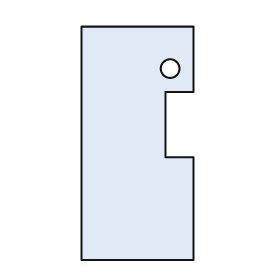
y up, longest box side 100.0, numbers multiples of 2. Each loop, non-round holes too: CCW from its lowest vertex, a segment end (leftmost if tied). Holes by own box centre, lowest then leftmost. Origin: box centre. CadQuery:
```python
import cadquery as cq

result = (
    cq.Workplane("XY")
    .moveTo(-24.0, -50.0)
    .lineTo(24.0, -50.0)
    .lineTo(24.0, -6.0)
    .lineTo(12.0, -6.0)
    .lineTo(12.0, 22.0)
    .lineTo(24.0, 22.0)
    .lineTo(24.0, 50.0)
    .lineTo(-24.0, 50.0)
    .close()
    .moveTo(14.0, 32.0)
    .circle(4.0)
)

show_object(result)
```